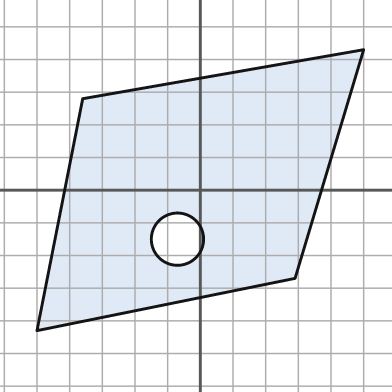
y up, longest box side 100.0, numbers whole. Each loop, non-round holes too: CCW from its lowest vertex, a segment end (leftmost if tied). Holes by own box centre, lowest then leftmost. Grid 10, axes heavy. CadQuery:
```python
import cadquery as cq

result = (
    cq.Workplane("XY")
    .moveTo(-50.0, -43.0)
    .lineTo(29.0, -27.0)
    .lineTo(50.0, 43.0)
    .lineTo(-36.0, 28.0)
    .close()
    .moveTo(-7.0, -15.0)
    .circle(8.0)
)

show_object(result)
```